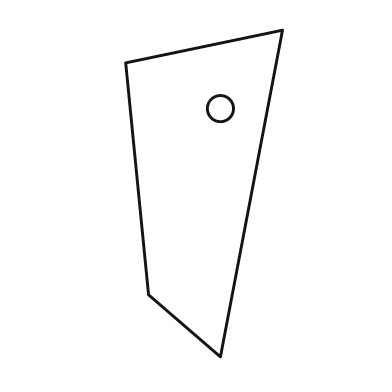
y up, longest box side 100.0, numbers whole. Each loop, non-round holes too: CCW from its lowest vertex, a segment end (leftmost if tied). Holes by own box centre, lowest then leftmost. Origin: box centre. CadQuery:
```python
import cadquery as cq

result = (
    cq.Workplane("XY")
    .moveTo(5.0, -50.0)
    .lineTo(24.0, 50.0)
    .lineTo(-24.0, 40.0)
    .lineTo(-17.0, -31.0)
    .close()
    .moveTo(5.0, 26.0)
    .circle(4.0)
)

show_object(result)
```